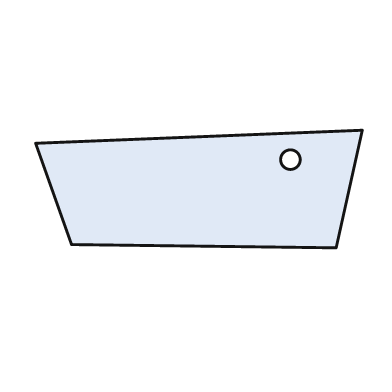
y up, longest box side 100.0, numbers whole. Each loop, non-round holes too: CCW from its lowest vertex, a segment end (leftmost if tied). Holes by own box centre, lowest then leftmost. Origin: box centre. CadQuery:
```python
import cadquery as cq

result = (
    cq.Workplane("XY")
    .moveTo(42.0, -18.0)
    .lineTo(50.0, 18.0)
    .lineTo(-50.0, 14.0)
    .lineTo(-39.0, -17.0)
    .close()
    .moveTo(28.0, 9.0)
    .circle(3.0)
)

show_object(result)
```